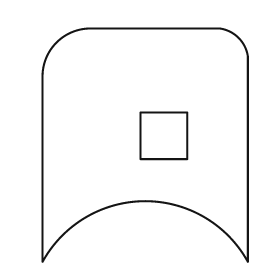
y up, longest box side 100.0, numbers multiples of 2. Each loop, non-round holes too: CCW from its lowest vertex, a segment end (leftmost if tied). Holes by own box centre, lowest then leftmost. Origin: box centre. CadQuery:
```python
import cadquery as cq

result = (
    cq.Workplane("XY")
    .moveTo(-44.0, -50.0)
    .threePointArc((0.0, -24.0), (44.0, -50.0))
    .lineTo(44.0, 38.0)
    .threePointArc((40.0, 46.0), (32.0, 50.0))
    .lineTo(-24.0, 50.0)
    .threePointArc((-38.0, 44.0), (-44.0, 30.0))
    .close()
    .moveTo(-2.0, -6.0)
    .lineTo(18.0, -6.0)
    .lineTo(18.0, 14.0)
    .lineTo(-2.0, 14.0)
    .close()
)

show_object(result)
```